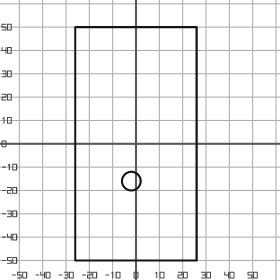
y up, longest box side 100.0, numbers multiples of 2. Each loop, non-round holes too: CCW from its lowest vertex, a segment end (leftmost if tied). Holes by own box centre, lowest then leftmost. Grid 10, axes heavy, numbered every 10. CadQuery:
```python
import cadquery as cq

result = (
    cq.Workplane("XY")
    .moveTo(-26.0, -50.0)
    .lineTo(26.0, -50.0)
    .lineTo(26.0, 50.0)
    .lineTo(-26.0, 50.0)
    .close()
    .moveTo(-2.0, -16.0)
    .circle(4.0)
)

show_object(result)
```